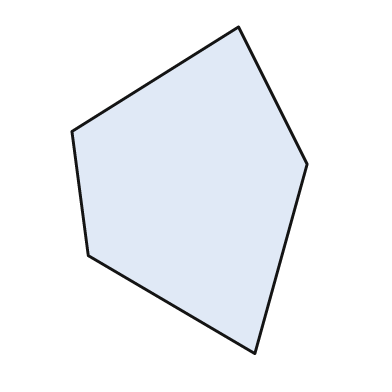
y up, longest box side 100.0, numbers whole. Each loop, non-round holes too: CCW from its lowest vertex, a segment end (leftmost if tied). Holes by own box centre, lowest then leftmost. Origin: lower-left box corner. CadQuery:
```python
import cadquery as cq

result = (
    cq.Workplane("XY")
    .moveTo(56.0, 0.0)
    .lineTo(72.0, 58.0)
    .lineTo(51.0, 100.0)
    .lineTo(0.0, 68.0)
    .lineTo(5.0, 30.0)
    .close()
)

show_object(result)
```